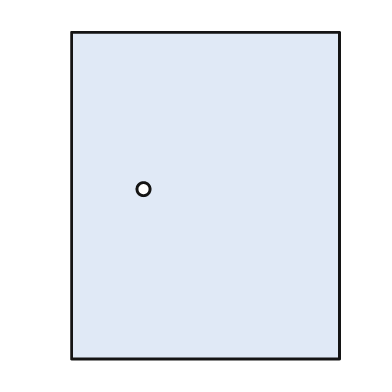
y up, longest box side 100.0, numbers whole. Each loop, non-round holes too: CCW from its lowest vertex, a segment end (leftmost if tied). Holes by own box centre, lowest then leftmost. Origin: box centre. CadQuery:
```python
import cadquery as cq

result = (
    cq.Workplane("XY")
    .moveTo(-41.0, -50.0)
    .lineTo(41.0, -50.0)
    .lineTo(41.0, 50.0)
    .lineTo(-41.0, 50.0)
    .close()
    .moveTo(-19.0, 2.0)
    .circle(2.0)
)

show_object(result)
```